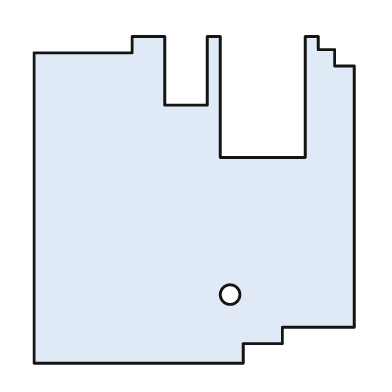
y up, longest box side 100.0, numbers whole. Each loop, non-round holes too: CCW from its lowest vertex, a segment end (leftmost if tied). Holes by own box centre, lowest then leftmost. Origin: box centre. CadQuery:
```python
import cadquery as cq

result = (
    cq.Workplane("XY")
    .moveTo(-49.0, -50.0)
    .lineTo(15.0, -50.0)
    .lineTo(15.0, -44.0)
    .lineTo(27.0, -44.0)
    .lineTo(27.0, -39.0)
    .lineTo(49.0, -39.0)
    .lineTo(49.0, 41.0)
    .lineTo(43.0, 41.0)
    .lineTo(43.0, 46.0)
    .lineTo(38.0, 46.0)
    .lineTo(38.0, 50.0)
    .lineTo(34.0, 50.0)
    .lineTo(34.0, 13.0)
    .lineTo(8.0, 13.0)
    .lineTo(8.0, 50.0)
    .lineTo(4.0, 50.0)
    .lineTo(4.0, 29.0)
    .lineTo(-9.0, 29.0)
    .lineTo(-9.0, 50.0)
    .lineTo(-19.0, 50.0)
    .lineTo(-19.0, 45.0)
    .lineTo(-49.0, 45.0)
    .close()
    .moveTo(11.0, -29.0)
    .circle(3.0)
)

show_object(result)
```